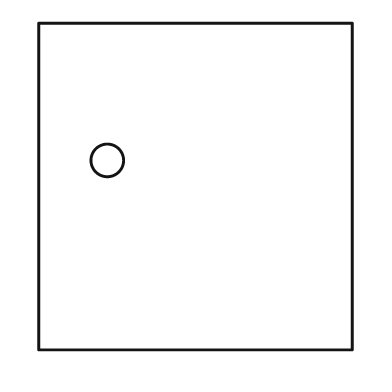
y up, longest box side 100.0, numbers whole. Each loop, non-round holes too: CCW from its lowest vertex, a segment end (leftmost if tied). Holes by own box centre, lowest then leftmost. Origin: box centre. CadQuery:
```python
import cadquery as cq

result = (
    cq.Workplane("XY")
    .moveTo(-48.0, -50.0)
    .lineTo(48.0, -50.0)
    .lineTo(48.0, 50.0)
    .lineTo(-48.0, 50.0)
    .close()
    .moveTo(-27.0, 8.0)
    .circle(5.0)
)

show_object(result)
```